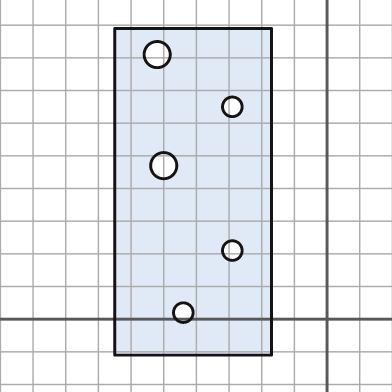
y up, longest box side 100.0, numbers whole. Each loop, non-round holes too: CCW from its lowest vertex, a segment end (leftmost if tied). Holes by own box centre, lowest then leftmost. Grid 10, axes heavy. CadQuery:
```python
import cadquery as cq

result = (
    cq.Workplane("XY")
    .moveTo(-65.0, -11.0)
    .lineTo(-17.0, -11.0)
    .lineTo(-17.0, 89.0)
    .lineTo(-65.0, 89.0)
    .close()
    .moveTo(-44.0, 2.0)
    .circle(3.0)
    .moveTo(-29.0, 21.0)
    .circle(3.0)
    .moveTo(-50.0, 47.0)
    .circle(4.0)
    .moveTo(-29.0, 65.0)
    .circle(3.0)
    .moveTo(-52.0, 81.0)
    .circle(4.0)
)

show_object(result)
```